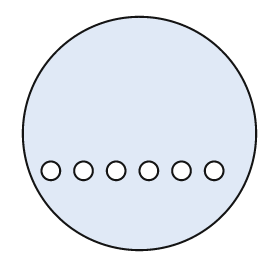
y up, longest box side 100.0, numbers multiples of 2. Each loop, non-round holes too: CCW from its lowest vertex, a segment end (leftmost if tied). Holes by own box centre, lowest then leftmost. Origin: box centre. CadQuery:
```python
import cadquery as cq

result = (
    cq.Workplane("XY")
    .moveTo(0.0, 0.0)
    .circle(50.0)
    .moveTo(-38.0, -16.0)
    .circle(4.0)
    .moveTo(-24.0, -16.0)
    .circle(4.0)
    .moveTo(-10.0, -16.0)
    .circle(4.0)
    .moveTo(4.0, -16.0)
    .circle(4.0)
    .moveTo(18.0, -16.0)
    .circle(4.0)
    .moveTo(32.0, -16.0)
    .circle(4.0)
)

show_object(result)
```